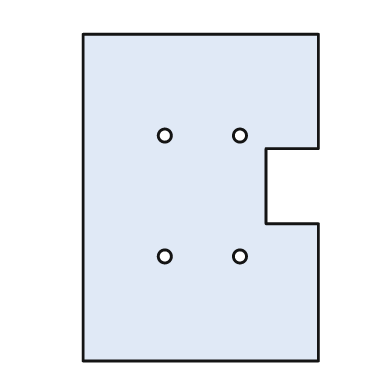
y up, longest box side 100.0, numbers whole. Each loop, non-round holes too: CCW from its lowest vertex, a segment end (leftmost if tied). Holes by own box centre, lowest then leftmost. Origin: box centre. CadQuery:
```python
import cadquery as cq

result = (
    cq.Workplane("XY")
    .moveTo(-36.0, -50.0)
    .lineTo(36.0, -50.0)
    .lineTo(36.0, -8.0)
    .lineTo(20.0, -8.0)
    .lineTo(20.0, 15.0)
    .lineTo(36.0, 15.0)
    .lineTo(36.0, 50.0)
    .lineTo(-36.0, 50.0)
    .close()
    .moveTo(-11.0, -18.0)
    .circle(2.0)
    .moveTo(12.0, -18.0)
    .circle(2.0)
    .moveTo(-11.0, 19.0)
    .circle(2.0)
    .moveTo(12.0, 19.0)
    .circle(2.0)
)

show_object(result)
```